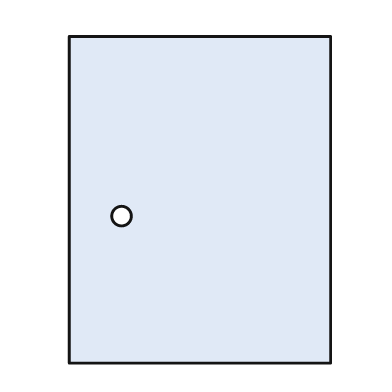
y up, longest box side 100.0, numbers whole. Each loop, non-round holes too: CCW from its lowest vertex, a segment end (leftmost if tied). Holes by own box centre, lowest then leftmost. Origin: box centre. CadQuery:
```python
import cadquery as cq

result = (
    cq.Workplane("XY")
    .moveTo(-40.0, -50.0)
    .lineTo(40.0, -50.0)
    .lineTo(40.0, 50.0)
    .lineTo(-40.0, 50.0)
    .close()
    .moveTo(-24.0, -5.0)
    .circle(3.0)
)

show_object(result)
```